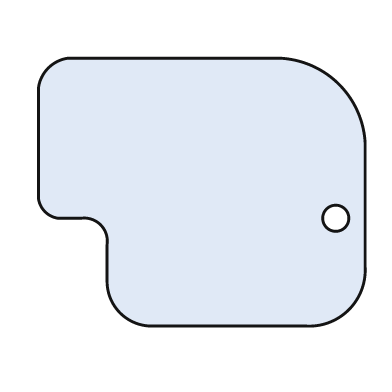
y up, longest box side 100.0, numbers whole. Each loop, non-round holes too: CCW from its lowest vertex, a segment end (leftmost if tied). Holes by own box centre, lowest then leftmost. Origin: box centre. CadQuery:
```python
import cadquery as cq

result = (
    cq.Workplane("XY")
    .moveTo(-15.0, -41.0)
    .lineTo(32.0, -41.0)
    .threePointArc((45.0, -36.0), (50.0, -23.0))
    .lineTo(50.0, 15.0)
    .threePointArc((42.0, 33.0), (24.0, 41.0))
    .lineTo(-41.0, 41.0)
    .threePointArc((-47.0, 38.0), (-50.0, 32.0))
    .lineTo(-50.0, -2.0)
    .threePointArc((-48.0, -6.0), (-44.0, -8.0))
    .lineTo(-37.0, -8.0)
    .threePointArc((-31.0, -10.0), (-29.0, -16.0))
    .lineTo(-29.0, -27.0)
    .threePointArc((-25.0, -37.0), (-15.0, -41.0))
    .close()
    .moveTo(41.0, -8.0)
    .circle(4.0)
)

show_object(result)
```